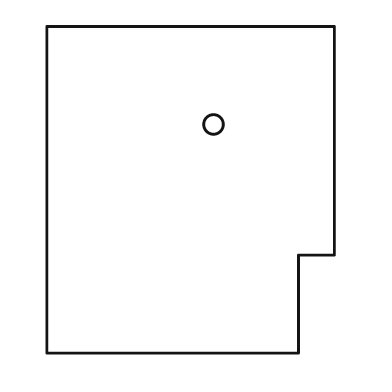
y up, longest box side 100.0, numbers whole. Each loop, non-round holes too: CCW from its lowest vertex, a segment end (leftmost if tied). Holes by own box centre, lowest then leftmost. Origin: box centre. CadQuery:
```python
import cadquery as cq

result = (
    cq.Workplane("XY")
    .moveTo(-44.0, -50.0)
    .lineTo(33.0, -50.0)
    .lineTo(33.0, -20.0)
    .lineTo(44.0, -20.0)
    .lineTo(44.0, 50.0)
    .lineTo(-44.0, 50.0)
    .close()
    .moveTo(7.0, 20.0)
    .circle(3.0)
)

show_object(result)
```